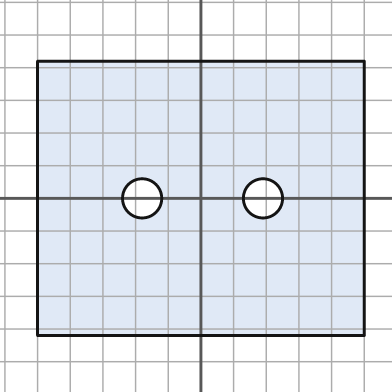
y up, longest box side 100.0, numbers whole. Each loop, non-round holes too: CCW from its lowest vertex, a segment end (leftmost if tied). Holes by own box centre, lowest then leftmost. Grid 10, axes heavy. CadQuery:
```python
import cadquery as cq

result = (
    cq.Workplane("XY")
    .moveTo(-50.0, -42.0)
    .lineTo(50.0, -42.0)
    .lineTo(50.0, 42.0)
    .lineTo(-50.0, 42.0)
    .close()
    .moveTo(-18.0, 0.0)
    .circle(6.0)
    .moveTo(19.0, 0.0)
    .circle(6.0)
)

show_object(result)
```